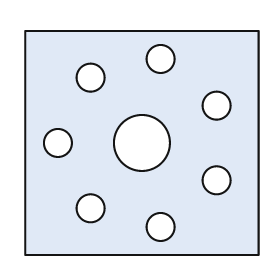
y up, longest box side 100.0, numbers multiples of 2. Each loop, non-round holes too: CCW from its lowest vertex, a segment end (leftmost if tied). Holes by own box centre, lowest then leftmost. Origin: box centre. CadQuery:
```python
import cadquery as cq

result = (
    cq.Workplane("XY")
    .moveTo(-50.0, -48.0)
    .lineTo(50.0, -48.0)
    .lineTo(50.0, 48.0)
    .lineTo(-50.0, 48.0)
    .close()
    .moveTo(8.0, -36.0)
    .circle(6.0)
    .moveTo(-22.0, -28.0)
    .circle(6.0)
    .moveTo(32.0, -16.0)
    .circle(6.0)
    .moveTo(-36.0, 0.0)
    .circle(6.0)
    .moveTo(0.0, 0.0)
    .circle(12.0)
    .moveTo(32.0, 16.0)
    .circle(6.0)
    .moveTo(-22.0, 28.0)
    .circle(6.0)
    .moveTo(8.0, 36.0)
    .circle(6.0)
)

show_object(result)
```